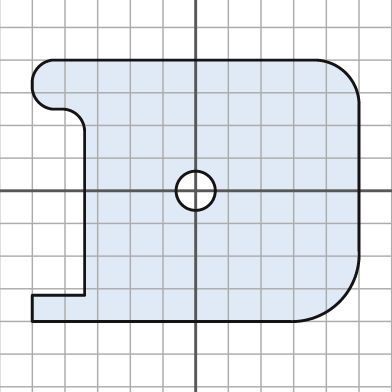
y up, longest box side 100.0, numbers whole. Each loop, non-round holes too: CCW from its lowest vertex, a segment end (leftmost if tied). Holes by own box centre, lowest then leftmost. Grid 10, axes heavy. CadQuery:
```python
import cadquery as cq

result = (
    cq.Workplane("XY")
    .moveTo(-50.0, -40.0)
    .lineTo(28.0, -40.0)
    .threePointArc((44.0, -34.0), (50.0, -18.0))
    .lineTo(50.0, 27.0)
    .threePointArc((46.0, 36.0), (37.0, 40.0))
    .lineTo(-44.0, 40.0)
    .threePointArc((-48.0, 38.0), (-50.0, 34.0))
    .lineTo(-50.0, 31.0)
    .threePointArc((-48.0, 27.0), (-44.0, 25.0))
    .lineTo(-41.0, 25.0)
    .threePointArc((-36.0, 23.0), (-34.0, 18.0))
    .lineTo(-34.0, -32.0)
    .lineTo(-50.0, -32.0)
    .close()
    .moveTo(0.0, 0.0)
    .circle(6.0)
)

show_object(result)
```